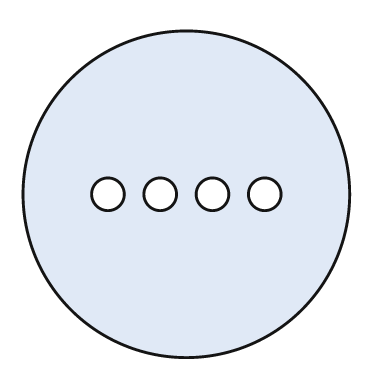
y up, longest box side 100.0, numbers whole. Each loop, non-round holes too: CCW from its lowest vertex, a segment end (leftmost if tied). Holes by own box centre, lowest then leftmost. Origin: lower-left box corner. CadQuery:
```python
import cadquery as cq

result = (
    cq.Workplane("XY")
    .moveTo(50.0, 50.0)
    .circle(50.0)
    .moveTo(26.0, 50.0)
    .circle(5.0)
    .moveTo(42.0, 50.0)
    .circle(5.0)
    .moveTo(58.0, 50.0)
    .circle(5.0)
    .moveTo(74.0, 50.0)
    .circle(5.0)
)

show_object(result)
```